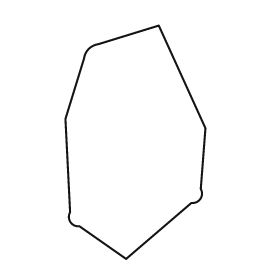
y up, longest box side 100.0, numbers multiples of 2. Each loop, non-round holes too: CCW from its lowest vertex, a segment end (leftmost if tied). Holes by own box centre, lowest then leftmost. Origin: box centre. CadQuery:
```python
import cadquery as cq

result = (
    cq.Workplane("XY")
    .moveTo(-4.0, -50.0)
    .lineTo(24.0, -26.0)
    .threePointArc((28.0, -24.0), (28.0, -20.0))
    .lineTo(30.0, 6.0)
    .lineTo(10.0, 50.0)
    .lineTo(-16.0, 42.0)
    .threePointArc((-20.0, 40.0), (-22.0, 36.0))
    .lineTo(-30.0, 10.0)
    .lineTo(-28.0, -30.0)
    .threePointArc((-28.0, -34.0), (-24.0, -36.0))
    .close()
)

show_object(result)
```